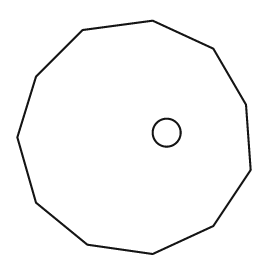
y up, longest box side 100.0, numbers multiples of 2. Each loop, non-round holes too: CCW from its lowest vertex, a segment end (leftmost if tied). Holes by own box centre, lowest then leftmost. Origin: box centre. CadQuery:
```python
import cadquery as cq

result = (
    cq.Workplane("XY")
    .moveTo(8.0, -50.0)
    .lineTo(34.0, -38.0)
    .lineTo(50.0, -14.0)
    .lineTo(48.0, 14.0)
    .lineTo(34.0, 38.0)
    .lineTo(8.0, 50.0)
    .lineTo(-22.0, 46.0)
    .lineTo(-42.0, 26.0)
    .lineTo(-50.0, 0.0)
    .lineTo(-42.0, -28.0)
    .lineTo(-20.0, -46.0)
    .close()
    .moveTo(14.0, 2.0)
    .circle(6.0)
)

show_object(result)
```